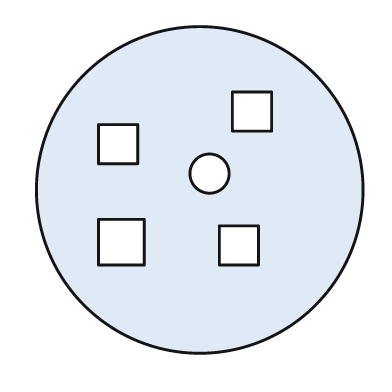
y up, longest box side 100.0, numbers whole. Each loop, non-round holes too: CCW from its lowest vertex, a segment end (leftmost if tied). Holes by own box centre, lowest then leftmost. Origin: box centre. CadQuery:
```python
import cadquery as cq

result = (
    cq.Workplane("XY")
    .moveTo(0.0, 0.0)
    .circle(50.0)
    .moveTo(6.0, -23.0)
    .lineTo(18.0, -23.0)
    .lineTo(18.0, -11.0)
    .lineTo(6.0, -11.0)
    .close()
    .moveTo(-31.0, -23.0)
    .lineTo(-17.0, -23.0)
    .lineTo(-17.0, -9.0)
    .lineTo(-31.0, -9.0)
    .close()
    .moveTo(3.0, 5.0)
    .circle(6.0)
    .moveTo(-31.0, 8.0)
    .lineTo(-19.0, 8.0)
    .lineTo(-19.0, 20.0)
    .lineTo(-31.0, 20.0)
    .close()
    .moveTo(10.0, 18.0)
    .lineTo(22.0, 18.0)
    .lineTo(22.0, 30.0)
    .lineTo(10.0, 30.0)
    .close()
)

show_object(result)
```